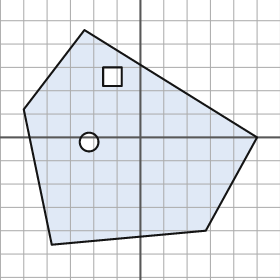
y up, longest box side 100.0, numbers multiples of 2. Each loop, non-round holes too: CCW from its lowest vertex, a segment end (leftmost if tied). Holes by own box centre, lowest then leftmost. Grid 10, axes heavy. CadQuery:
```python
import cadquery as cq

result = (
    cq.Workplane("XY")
    .moveTo(-38.0, -46.0)
    .lineTo(28.0, -40.0)
    .lineTo(50.0, 0.0)
    .lineTo(-24.0, 46.0)
    .lineTo(-50.0, 12.0)
    .close()
    .moveTo(-22.0, -2.0)
    .circle(4.0)
    .moveTo(-16.0, 22.0)
    .lineTo(-8.0, 22.0)
    .lineTo(-8.0, 30.0)
    .lineTo(-16.0, 30.0)
    .close()
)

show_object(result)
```